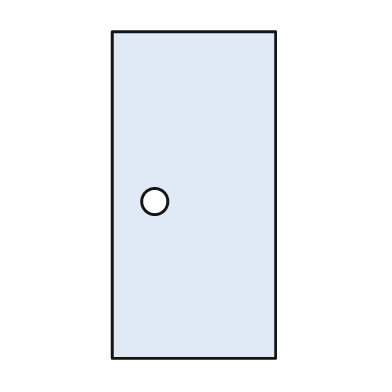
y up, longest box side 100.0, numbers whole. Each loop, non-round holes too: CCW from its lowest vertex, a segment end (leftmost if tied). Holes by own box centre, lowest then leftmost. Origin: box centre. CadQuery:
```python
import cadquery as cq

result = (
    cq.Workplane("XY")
    .moveTo(-25.0, -50.0)
    .lineTo(25.0, -50.0)
    .lineTo(25.0, 50.0)
    .lineTo(-25.0, 50.0)
    .close()
    .moveTo(-12.0, -2.0)
    .circle(4.0)
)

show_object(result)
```